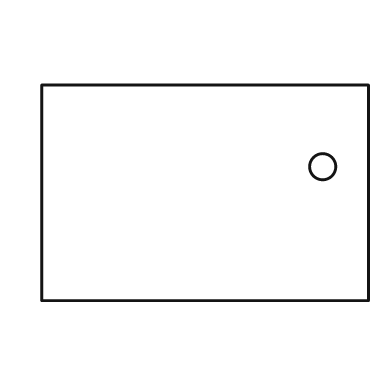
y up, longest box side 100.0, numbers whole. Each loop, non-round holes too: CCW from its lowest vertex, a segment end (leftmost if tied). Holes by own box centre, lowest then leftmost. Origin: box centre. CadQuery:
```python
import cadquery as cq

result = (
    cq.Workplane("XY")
    .moveTo(-50.0, -33.0)
    .lineTo(50.0, -33.0)
    .lineTo(50.0, 33.0)
    .lineTo(-50.0, 33.0)
    .close()
    .moveTo(36.0, 8.0)
    .circle(4.0)
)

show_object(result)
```